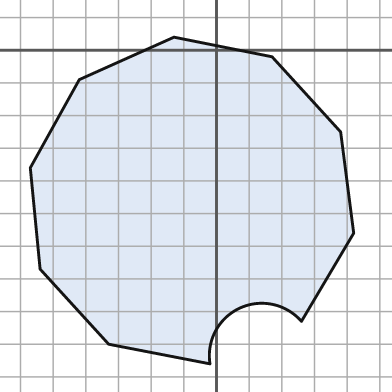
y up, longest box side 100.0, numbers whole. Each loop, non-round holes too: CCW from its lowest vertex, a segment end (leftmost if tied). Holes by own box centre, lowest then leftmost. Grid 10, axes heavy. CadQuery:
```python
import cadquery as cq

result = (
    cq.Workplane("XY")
    .moveTo(-2.0, -96.0)
    .threePointArc((7.0, -79.0), (26.0, -83.0))
    .lineTo(42.0, -56.0)
    .lineTo(38.0, -25.0)
    .lineTo(17.0, -2.0)
    .lineTo(-13.0, 4.0)
    .lineTo(-42.0, -9.0)
    .lineTo(-57.0, -36.0)
    .lineTo(-54.0, -67.0)
    .lineTo(-33.0, -90.0)
    .close()
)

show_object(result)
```